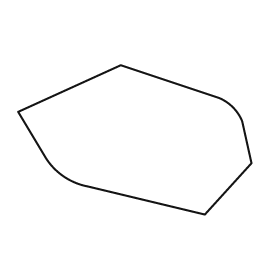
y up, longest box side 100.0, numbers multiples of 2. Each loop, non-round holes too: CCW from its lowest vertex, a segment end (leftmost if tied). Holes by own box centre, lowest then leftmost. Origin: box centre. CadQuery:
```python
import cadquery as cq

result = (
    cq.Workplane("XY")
    .moveTo(30.0, -32.0)
    .lineTo(50.0, -10.0)
    .lineTo(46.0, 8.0)
    .threePointArc((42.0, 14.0), (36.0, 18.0))
    .lineTo(-6.0, 32.0)
    .lineTo(-50.0, 12.0)
    .lineTo(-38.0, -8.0)
    .threePointArc((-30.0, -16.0), (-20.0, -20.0))
    .close()
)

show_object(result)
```